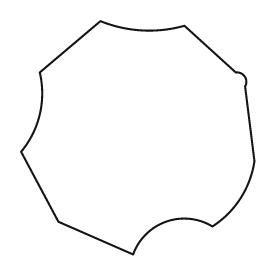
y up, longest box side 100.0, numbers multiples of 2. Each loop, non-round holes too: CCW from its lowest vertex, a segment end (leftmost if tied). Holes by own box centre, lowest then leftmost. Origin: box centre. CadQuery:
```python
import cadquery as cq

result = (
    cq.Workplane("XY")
    .moveTo(-2.0, -50.0)
    .threePointArc((12.0, -36.0), (32.0, -38.0))
    .threePointArc((44.0, -26.0), (50.0, -10.0))
    .lineTo(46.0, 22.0)
    .threePointArc((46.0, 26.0), (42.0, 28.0))
    .lineTo(20.0, 48.0)
    .threePointArc((2.0, 46.0), (-16.0, 50.0))
    .lineTo(-42.0, 28.0)
    .threePointArc((-42.0, 10.0), (-50.0, -6.0))
    .lineTo(-34.0, -36.0)
    .close()
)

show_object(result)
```